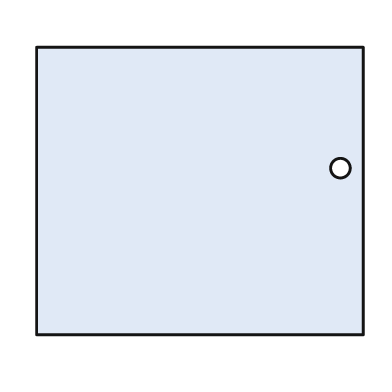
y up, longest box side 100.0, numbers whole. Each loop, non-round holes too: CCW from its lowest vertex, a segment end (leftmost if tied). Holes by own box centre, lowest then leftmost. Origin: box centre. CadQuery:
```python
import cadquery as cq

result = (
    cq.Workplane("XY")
    .moveTo(-50.0, -44.0)
    .lineTo(50.0, -44.0)
    .lineTo(50.0, 44.0)
    .lineTo(-50.0, 44.0)
    .close()
    .moveTo(43.0, 7.0)
    .circle(3.0)
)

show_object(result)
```